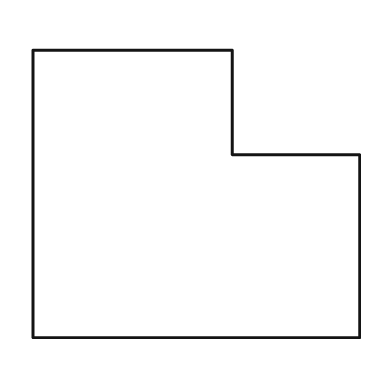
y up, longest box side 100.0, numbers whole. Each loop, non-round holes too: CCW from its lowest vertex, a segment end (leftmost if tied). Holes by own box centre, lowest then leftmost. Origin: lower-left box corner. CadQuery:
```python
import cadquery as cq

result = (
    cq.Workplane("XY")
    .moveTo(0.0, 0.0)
    .lineTo(100.0, 0.0)
    .lineTo(100.0, 56.0)
    .lineTo(61.0, 56.0)
    .lineTo(61.0, 88.0)
    .lineTo(0.0, 88.0)
    .close()
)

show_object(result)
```